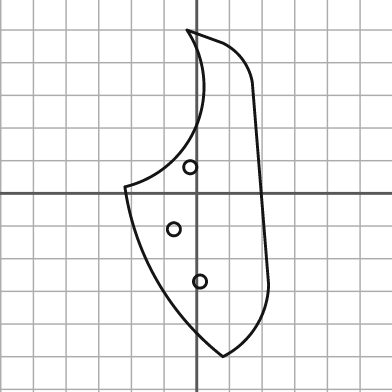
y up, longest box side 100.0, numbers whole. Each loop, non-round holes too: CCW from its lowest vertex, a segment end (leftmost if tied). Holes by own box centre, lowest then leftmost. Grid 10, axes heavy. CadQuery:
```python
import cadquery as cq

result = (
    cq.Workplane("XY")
    .moveTo(8.0, -50.0)
    .threePointArc((18.0, -41.0), (22.0, -28.0))
    .lineTo(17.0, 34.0)
    .threePointArc((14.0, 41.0), (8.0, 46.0))
    .lineTo(-3.0, 50.0)
    .threePointArc((0.0, 21.0), (-22.0, 2.0))
    .threePointArc((-12.0, -27.0), (8.0, -50.0))
    .close()
    .moveTo(1.0, -27.0)
    .circle(2.0)
    .moveTo(-7.0, -11.0)
    .circle(2.0)
    .moveTo(-2.0, 8.0)
    .circle(2.0)
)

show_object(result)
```